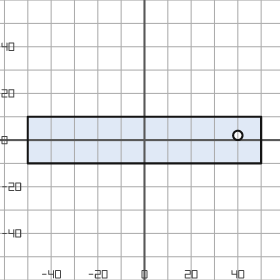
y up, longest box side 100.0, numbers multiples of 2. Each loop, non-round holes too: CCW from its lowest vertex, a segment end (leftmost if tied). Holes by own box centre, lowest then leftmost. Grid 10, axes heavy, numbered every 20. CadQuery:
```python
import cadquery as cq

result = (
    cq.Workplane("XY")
    .moveTo(-50.0, -10.0)
    .lineTo(50.0, -10.0)
    .lineTo(50.0, 10.0)
    .lineTo(-50.0, 10.0)
    .close()
    .moveTo(40.0, 2.0)
    .circle(2.0)
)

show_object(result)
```